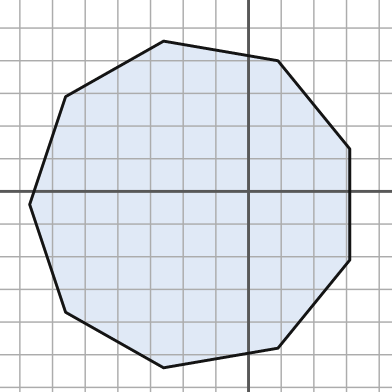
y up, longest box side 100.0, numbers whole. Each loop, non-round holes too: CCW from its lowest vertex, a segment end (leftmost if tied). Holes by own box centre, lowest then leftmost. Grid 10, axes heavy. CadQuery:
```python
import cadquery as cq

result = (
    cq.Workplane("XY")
    .moveTo(-26.0, -54.0)
    .lineTo(9.0, -48.0)
    .lineTo(31.0, -21.0)
    .lineTo(31.0, 13.0)
    .lineTo(9.0, 40.0)
    .lineTo(-26.0, 46.0)
    .lineTo(-56.0, 29.0)
    .lineTo(-67.0, -4.0)
    .lineTo(-56.0, -37.0)
    .close()
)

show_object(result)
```